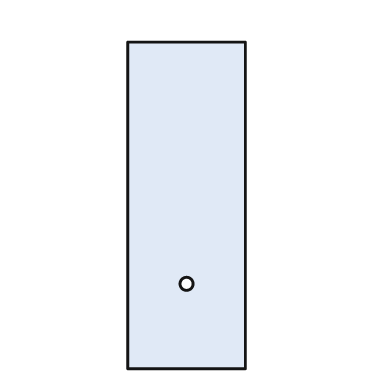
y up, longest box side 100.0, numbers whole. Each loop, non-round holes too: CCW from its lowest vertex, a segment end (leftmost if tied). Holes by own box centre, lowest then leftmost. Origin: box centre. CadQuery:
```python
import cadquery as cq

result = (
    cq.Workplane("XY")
    .moveTo(-18.0, -50.0)
    .lineTo(18.0, -50.0)
    .lineTo(18.0, 50.0)
    .lineTo(-18.0, 50.0)
    .close()
    .moveTo(0.0, -24.0)
    .circle(2.0)
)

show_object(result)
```